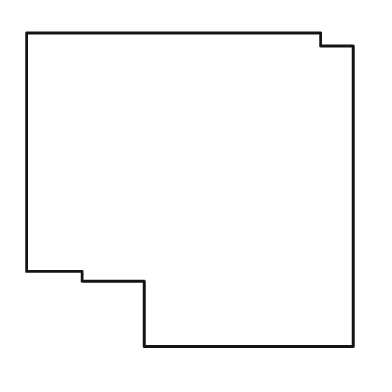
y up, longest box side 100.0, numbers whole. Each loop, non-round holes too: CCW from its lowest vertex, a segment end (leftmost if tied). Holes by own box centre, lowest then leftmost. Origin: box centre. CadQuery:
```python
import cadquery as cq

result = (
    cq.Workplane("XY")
    .moveTo(-14.0, -48.0)
    .lineTo(50.0, -48.0)
    .lineTo(50.0, 44.0)
    .lineTo(40.0, 44.0)
    .lineTo(40.0, 48.0)
    .lineTo(-50.0, 48.0)
    .lineTo(-50.0, -25.0)
    .lineTo(-33.0, -25.0)
    .lineTo(-33.0, -28.0)
    .lineTo(-14.0, -28.0)
    .close()
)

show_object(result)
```